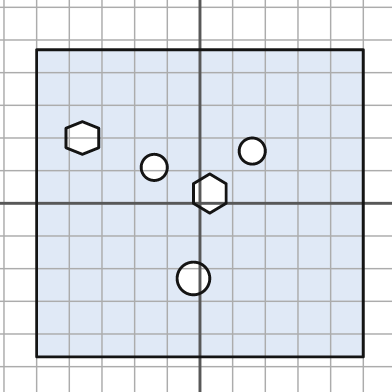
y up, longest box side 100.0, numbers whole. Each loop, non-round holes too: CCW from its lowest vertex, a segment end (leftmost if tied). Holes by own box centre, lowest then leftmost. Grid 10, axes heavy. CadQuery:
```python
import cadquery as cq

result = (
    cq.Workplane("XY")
    .moveTo(-50.0, -47.0)
    .lineTo(50.0, -47.0)
    .lineTo(50.0, 47.0)
    .lineTo(-50.0, 47.0)
    .close()
    .moveTo(-2.0, -23.0)
    .circle(5.0)
    .moveTo(3.0, -3.0)
    .lineTo(8.0, 0.0)
    .lineTo(8.0, 6.0)
    .lineTo(3.0, 9.0)
    .lineTo(-2.0, 6.0)
    .lineTo(-2.0, 0.0)
    .close()
    .moveTo(-14.0, 11.0)
    .circle(4.0)
    .moveTo(16.0, 16.0)
    .circle(4.0)
    .moveTo(-36.0, 15.0)
    .lineTo(-31.0, 17.0)
    .lineTo(-31.0, 23.0)
    .lineTo(-36.0, 25.0)
    .lineTo(-41.0, 23.0)
    .lineTo(-41.0, 17.0)
    .close()
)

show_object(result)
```